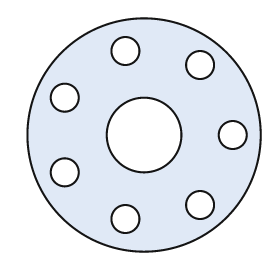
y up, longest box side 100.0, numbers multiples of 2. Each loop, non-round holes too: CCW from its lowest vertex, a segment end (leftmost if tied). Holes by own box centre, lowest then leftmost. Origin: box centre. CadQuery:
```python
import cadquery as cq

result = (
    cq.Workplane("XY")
    .moveTo(0.0, 0.0)
    .circle(50.0)
    .moveTo(-8.0, -36.0)
    .circle(6.0)
    .moveTo(24.0, -30.0)
    .circle(6.0)
    .moveTo(-34.0, -16.0)
    .circle(6.0)
    .moveTo(0.0, 0.0)
    .circle(16.0)
    .moveTo(38.0, 0.0)
    .circle(6.0)
    .moveTo(-34.0, 16.0)
    .circle(6.0)
    .moveTo(24.0, 30.0)
    .circle(6.0)
    .moveTo(-8.0, 36.0)
    .circle(6.0)
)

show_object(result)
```